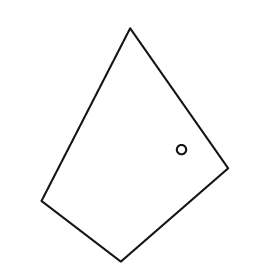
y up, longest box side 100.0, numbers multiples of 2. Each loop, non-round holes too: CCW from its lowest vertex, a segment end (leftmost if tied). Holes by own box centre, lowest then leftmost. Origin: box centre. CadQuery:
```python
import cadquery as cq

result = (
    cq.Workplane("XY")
    .moveTo(-6.0, -50.0)
    .lineTo(40.0, -10.0)
    .lineTo(-2.0, 50.0)
    .lineTo(-40.0, -24.0)
    .close()
    .moveTo(20.0, -2.0)
    .circle(2.0)
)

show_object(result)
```